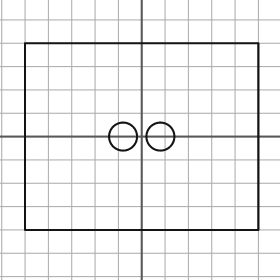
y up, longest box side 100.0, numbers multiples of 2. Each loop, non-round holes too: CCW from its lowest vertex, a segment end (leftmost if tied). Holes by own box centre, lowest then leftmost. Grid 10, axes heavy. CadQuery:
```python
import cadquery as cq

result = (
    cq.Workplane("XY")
    .moveTo(-50.0, -40.0)
    .lineTo(50.0, -40.0)
    .lineTo(50.0, 40.0)
    .lineTo(-50.0, 40.0)
    .close()
    .moveTo(-8.0, 0.0)
    .circle(6.0)
    .moveTo(8.0, 0.0)
    .circle(6.0)
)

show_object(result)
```